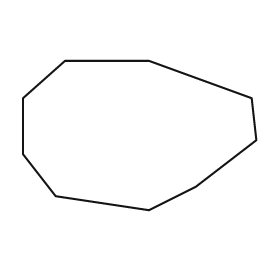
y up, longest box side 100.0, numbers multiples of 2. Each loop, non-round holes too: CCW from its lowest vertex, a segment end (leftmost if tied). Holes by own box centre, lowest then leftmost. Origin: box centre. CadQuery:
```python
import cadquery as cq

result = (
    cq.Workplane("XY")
    .moveTo(4.0, -32.0)
    .lineTo(24.0, -22.0)
    .lineTo(50.0, -2.0)
    .lineTo(48.0, 16.0)
    .lineTo(4.0, 32.0)
    .lineTo(-32.0, 32.0)
    .lineTo(-50.0, 16.0)
    .lineTo(-50.0, -8.0)
    .lineTo(-36.0, -26.0)
    .close()
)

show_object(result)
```